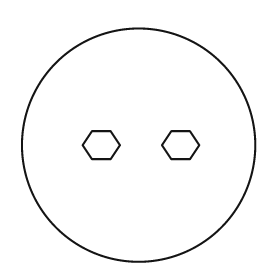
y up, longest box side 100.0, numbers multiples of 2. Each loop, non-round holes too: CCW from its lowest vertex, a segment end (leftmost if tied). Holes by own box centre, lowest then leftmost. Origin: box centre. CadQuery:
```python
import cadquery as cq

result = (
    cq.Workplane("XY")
    .moveTo(0.0, 0.0)
    .circle(50.0)
    .moveTo(-20.0, -6.0)
    .lineTo(-12.0, -6.0)
    .lineTo(-8.0, 0.0)
    .lineTo(-12.0, 6.0)
    .lineTo(-20.0, 6.0)
    .lineTo(-24.0, 0.0)
    .close()
    .moveTo(14.0, -6.0)
    .lineTo(22.0, -6.0)
    .lineTo(26.0, 0.0)
    .lineTo(22.0, 6.0)
    .lineTo(14.0, 6.0)
    .lineTo(10.0, 0.0)
    .close()
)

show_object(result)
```